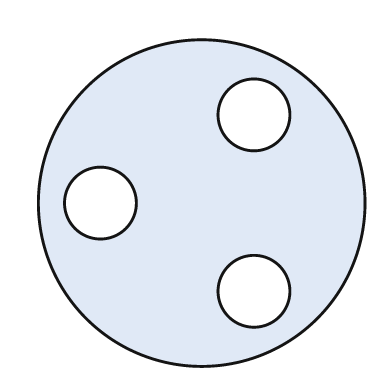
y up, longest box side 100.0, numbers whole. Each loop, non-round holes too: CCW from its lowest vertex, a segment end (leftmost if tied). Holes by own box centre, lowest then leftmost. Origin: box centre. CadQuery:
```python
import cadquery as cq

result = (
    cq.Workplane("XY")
    .moveTo(0.0, 0.0)
    .circle(50.0)
    .moveTo(16.0, -27.0)
    .circle(11.0)
    .moveTo(-31.0, 0.0)
    .circle(11.0)
    .moveTo(16.0, 27.0)
    .circle(11.0)
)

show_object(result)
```